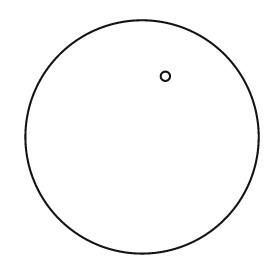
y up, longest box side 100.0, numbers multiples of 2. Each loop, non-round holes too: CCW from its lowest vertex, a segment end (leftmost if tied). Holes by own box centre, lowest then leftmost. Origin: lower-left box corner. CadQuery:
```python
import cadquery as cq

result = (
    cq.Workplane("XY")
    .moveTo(50.0, 50.0)
    .circle(50.0)
    .moveTo(60.0, 76.0)
    .circle(2.0)
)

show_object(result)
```